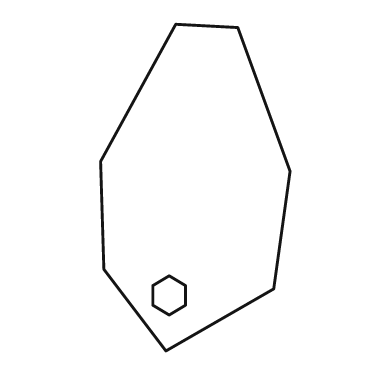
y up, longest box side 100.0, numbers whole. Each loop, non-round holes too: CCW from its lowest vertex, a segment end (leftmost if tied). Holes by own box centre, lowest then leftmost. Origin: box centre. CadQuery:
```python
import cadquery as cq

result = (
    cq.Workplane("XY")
    .moveTo(-9.0, -50.0)
    .lineTo(24.0, -31.0)
    .lineTo(29.0, 5.0)
    .lineTo(13.0, 49.0)
    .lineTo(-6.0, 50.0)
    .lineTo(-29.0, 8.0)
    .lineTo(-28.0, -25.0)
    .close()
    .moveTo(-8.0, -39.0)
    .lineTo(-3.0, -36.0)
    .lineTo(-3.0, -30.0)
    .lineTo(-8.0, -27.0)
    .lineTo(-13.0, -30.0)
    .lineTo(-13.0, -36.0)
    .close()
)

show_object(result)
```